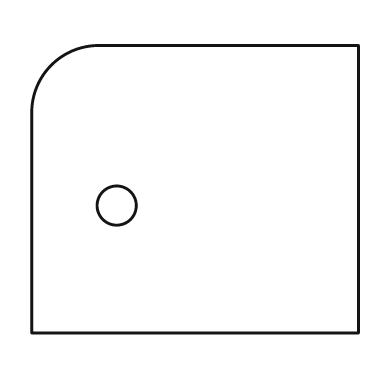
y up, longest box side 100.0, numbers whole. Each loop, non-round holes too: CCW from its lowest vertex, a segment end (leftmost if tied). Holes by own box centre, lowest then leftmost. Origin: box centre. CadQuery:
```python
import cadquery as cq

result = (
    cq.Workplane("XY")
    .moveTo(-50.0, -44.0)
    .lineTo(50.0, -44.0)
    .lineTo(50.0, 44.0)
    .lineTo(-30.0, 44.0)
    .threePointArc((-44.0, 38.0), (-50.0, 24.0))
    .close()
    .moveTo(-24.0, -5.0)
    .circle(6.0)
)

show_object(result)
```